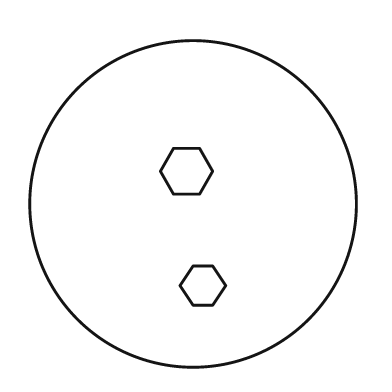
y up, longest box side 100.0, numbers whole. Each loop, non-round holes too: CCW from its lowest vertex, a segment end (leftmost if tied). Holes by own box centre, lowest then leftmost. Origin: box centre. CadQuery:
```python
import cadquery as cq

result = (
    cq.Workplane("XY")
    .moveTo(0.0, 0.0)
    .circle(50.0)
    .moveTo(0.0, -31.0)
    .lineTo(6.0, -31.0)
    .lineTo(10.0, -25.0)
    .lineTo(6.0, -19.0)
    .lineTo(0.0, -19.0)
    .lineTo(-4.0, -25.0)
    .close()
    .moveTo(-6.0, 3.0)
    .lineTo(2.0, 3.0)
    .lineTo(6.0, 10.0)
    .lineTo(2.0, 17.0)
    .lineTo(-6.0, 17.0)
    .lineTo(-10.0, 10.0)
    .close()
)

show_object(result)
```